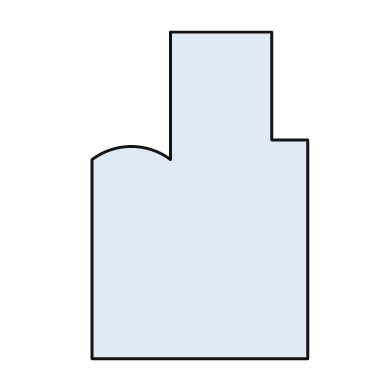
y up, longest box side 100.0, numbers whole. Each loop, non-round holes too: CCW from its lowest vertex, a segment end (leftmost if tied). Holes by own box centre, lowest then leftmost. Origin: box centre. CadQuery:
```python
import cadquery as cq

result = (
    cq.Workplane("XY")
    .moveTo(-33.0, -50.0)
    .lineTo(33.0, -50.0)
    .lineTo(33.0, 17.0)
    .lineTo(22.0, 17.0)
    .lineTo(22.0, 50.0)
    .lineTo(-9.0, 50.0)
    .lineTo(-9.0, 11.0)
    .threePointArc((-21.0, 15.0), (-33.0, 11.0))
    .close()
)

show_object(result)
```